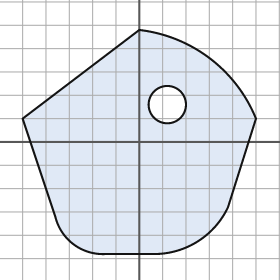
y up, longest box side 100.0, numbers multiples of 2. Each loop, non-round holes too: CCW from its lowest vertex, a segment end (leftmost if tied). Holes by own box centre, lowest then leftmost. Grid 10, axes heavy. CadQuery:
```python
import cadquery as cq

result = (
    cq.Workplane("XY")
    .moveTo(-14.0, -48.0)
    .lineTo(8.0, -48.0)
    .threePointArc((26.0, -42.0), (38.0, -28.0))
    .lineTo(50.0, 10.0)
    .threePointArc((30.0, 36.0), (0.0, 48.0))
    .lineTo(-50.0, 10.0)
    .lineTo(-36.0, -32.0)
    .threePointArc((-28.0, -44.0), (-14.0, -48.0))
    .close()
    .moveTo(12.0, 16.0)
    .circle(8.0)
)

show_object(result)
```